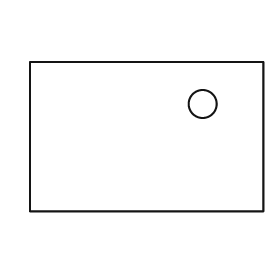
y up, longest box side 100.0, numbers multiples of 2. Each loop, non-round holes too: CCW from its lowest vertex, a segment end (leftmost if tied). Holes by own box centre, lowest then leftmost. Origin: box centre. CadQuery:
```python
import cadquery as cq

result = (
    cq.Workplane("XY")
    .moveTo(-50.0, -32.0)
    .lineTo(50.0, -32.0)
    .lineTo(50.0, 32.0)
    .lineTo(-50.0, 32.0)
    .close()
    .moveTo(24.0, 14.0)
    .circle(6.0)
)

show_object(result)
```